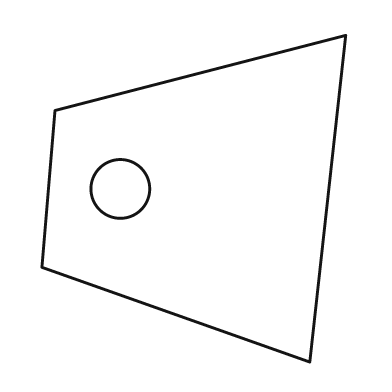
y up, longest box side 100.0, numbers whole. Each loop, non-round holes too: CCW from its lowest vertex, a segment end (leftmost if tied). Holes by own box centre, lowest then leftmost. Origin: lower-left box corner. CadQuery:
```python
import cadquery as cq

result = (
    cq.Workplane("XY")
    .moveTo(82.0, 0.0)
    .lineTo(93.0, 100.0)
    .lineTo(4.0, 77.0)
    .lineTo(0.0, 29.0)
    .close()
    .moveTo(24.0, 53.0)
    .circle(9.0)
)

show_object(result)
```